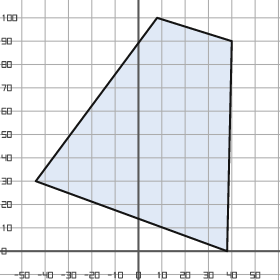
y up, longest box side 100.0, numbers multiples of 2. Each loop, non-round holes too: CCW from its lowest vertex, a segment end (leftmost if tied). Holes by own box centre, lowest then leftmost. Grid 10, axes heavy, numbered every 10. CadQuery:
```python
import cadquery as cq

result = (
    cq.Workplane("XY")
    .moveTo(38.0, 0.0)
    .lineTo(40.0, 90.0)
    .lineTo(8.0, 100.0)
    .lineTo(-44.0, 30.0)
    .close()
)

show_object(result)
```